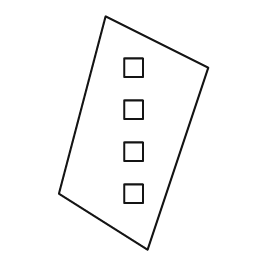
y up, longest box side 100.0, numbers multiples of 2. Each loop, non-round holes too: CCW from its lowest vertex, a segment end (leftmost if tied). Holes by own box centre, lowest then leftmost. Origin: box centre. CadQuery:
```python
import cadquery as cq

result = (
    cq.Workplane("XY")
    .moveTo(6.0, -50.0)
    .lineTo(32.0, 28.0)
    .lineTo(-12.0, 50.0)
    .lineTo(-32.0, -26.0)
    .close()
    .moveTo(-4.0, -30.0)
    .lineTo(4.0, -30.0)
    .lineTo(4.0, -22.0)
    .lineTo(-4.0, -22.0)
    .close()
    .moveTo(-4.0, -12.0)
    .lineTo(4.0, -12.0)
    .lineTo(4.0, -4.0)
    .lineTo(-4.0, -4.0)
    .close()
    .moveTo(-4.0, 6.0)
    .lineTo(4.0, 6.0)
    .lineTo(4.0, 14.0)
    .lineTo(-4.0, 14.0)
    .close()
    .moveTo(-4.0, 24.0)
    .lineTo(4.0, 24.0)
    .lineTo(4.0, 32.0)
    .lineTo(-4.0, 32.0)
    .close()
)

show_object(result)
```